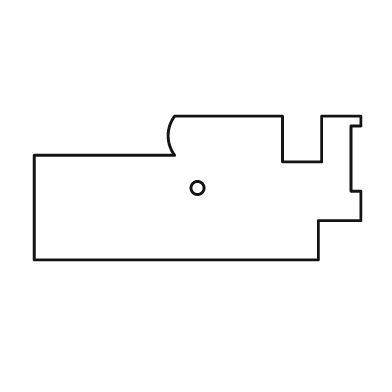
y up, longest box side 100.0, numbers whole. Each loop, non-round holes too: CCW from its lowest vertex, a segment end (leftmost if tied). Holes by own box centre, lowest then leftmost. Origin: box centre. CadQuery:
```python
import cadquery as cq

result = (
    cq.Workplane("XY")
    .moveTo(-50.0, -22.0)
    .lineTo(37.0, -22.0)
    .lineTo(37.0, -10.0)
    .lineTo(50.0, -10.0)
    .lineTo(50.0, -1.0)
    .lineTo(47.0, -1.0)
    .lineTo(47.0, 19.0)
    .lineTo(50.0, 19.0)
    .lineTo(50.0, 22.0)
    .lineTo(38.0, 22.0)
    .lineTo(38.0, 8.0)
    .lineTo(26.0, 8.0)
    .lineTo(26.0, 22.0)
    .lineTo(-7.0, 22.0)
    .threePointArc((-9.0, 16.0), (-7.0, 10.0))
    .lineTo(-50.0, 10.0)
    .close()
    .moveTo(0.0, 0.0)
    .circle(2.0)
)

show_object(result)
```